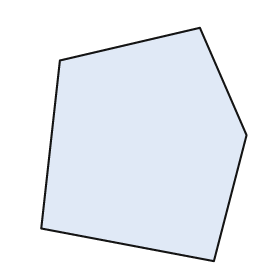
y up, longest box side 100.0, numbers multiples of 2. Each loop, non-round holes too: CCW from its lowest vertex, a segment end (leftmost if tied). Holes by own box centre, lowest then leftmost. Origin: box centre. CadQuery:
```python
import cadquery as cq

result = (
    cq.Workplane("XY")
    .moveTo(30.0, -50.0)
    .lineTo(44.0, 4.0)
    .lineTo(24.0, 50.0)
    .lineTo(-36.0, 36.0)
    .lineTo(-44.0, -36.0)
    .close()
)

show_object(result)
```